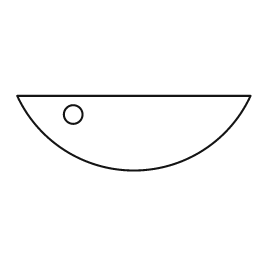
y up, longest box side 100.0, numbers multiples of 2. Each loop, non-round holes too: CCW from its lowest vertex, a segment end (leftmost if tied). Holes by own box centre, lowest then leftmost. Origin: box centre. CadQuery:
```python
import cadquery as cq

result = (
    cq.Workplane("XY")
    .moveTo(-50.0, 16.0)
    .threePointArc((0.0, -16.0), (50.0, 16.0))
    .close()
    .moveTo(-26.0, 8.0)
    .circle(4.0)
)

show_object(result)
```